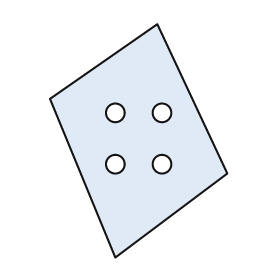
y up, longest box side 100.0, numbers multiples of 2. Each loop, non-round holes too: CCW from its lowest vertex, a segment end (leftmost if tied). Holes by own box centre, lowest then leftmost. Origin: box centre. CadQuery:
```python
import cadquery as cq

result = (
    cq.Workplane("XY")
    .moveTo(-10.0, -50.0)
    .lineTo(38.0, -14.0)
    .lineTo(8.0, 50.0)
    .lineTo(-38.0, 18.0)
    .close()
    .moveTo(-10.0, -10.0)
    .circle(4.0)
    .moveTo(10.0, -10.0)
    .circle(4.0)
    .moveTo(-10.0, 12.0)
    .circle(4.0)
    .moveTo(10.0, 12.0)
    .circle(4.0)
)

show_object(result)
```